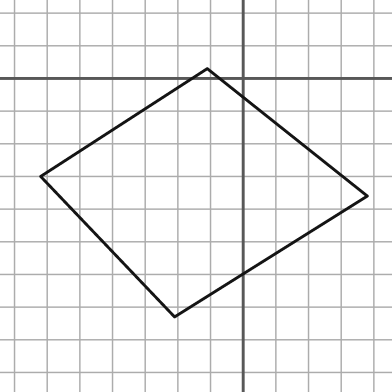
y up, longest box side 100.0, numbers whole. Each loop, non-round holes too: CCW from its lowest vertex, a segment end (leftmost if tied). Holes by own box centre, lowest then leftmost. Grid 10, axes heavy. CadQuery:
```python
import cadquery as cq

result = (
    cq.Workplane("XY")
    .moveTo(-21.0, -73.0)
    .lineTo(38.0, -36.0)
    .lineTo(-11.0, 3.0)
    .lineTo(-62.0, -30.0)
    .close()
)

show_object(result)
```